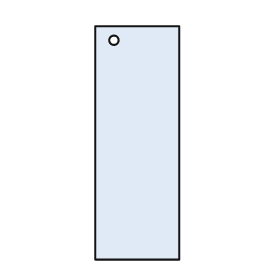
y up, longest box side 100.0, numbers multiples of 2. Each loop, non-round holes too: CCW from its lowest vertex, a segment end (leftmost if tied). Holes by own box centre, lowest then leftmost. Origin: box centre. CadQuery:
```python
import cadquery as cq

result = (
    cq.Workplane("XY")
    .moveTo(-18.0, -50.0)
    .lineTo(18.0, -50.0)
    .lineTo(18.0, 50.0)
    .lineTo(-18.0, 50.0)
    .close()
    .moveTo(-10.0, 44.0)
    .circle(2.0)
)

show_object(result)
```